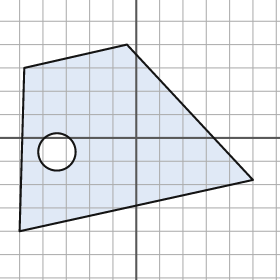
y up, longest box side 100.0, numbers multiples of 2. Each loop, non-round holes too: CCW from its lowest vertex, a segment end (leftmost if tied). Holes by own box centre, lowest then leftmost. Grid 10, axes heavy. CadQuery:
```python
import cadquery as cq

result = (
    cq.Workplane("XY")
    .moveTo(-50.0, -40.0)
    .lineTo(50.0, -18.0)
    .lineTo(-4.0, 40.0)
    .lineTo(-48.0, 30.0)
    .close()
    .moveTo(-34.0, -6.0)
    .circle(8.0)
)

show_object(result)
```